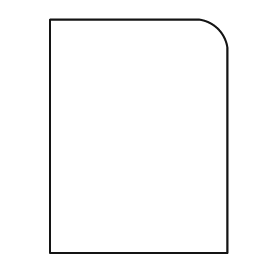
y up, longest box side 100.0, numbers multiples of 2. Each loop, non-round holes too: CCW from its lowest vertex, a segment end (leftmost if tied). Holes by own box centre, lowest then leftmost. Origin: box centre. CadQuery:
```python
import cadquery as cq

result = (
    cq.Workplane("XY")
    .moveTo(-38.0, -50.0)
    .lineTo(38.0, -50.0)
    .lineTo(38.0, 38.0)
    .threePointArc((34.0, 46.0), (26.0, 50.0))
    .lineTo(-38.0, 50.0)
    .close()
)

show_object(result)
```